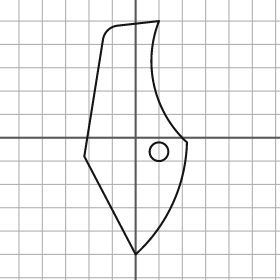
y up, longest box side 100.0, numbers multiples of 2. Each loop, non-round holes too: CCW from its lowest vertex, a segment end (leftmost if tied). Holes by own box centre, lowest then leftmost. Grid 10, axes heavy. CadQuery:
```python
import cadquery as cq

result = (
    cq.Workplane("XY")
    .moveTo(0.0, -50.0)
    .threePointArc((16.0, -28.0), (22.0, -2.0))
    .threePointArc((8.0, 22.0), (10.0, 50.0))
    .lineTo(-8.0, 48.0)
    .threePointArc((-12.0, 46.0), (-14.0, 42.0))
    .lineTo(-22.0, -8.0)
    .close()
    .moveTo(10.0, -6.0)
    .circle(4.0)
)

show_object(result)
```